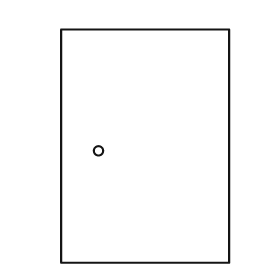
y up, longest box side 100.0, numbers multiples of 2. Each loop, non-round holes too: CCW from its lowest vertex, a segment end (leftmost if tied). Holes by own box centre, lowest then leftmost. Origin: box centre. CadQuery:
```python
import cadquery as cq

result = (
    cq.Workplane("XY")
    .moveTo(-36.0, -50.0)
    .lineTo(36.0, -50.0)
    .lineTo(36.0, 50.0)
    .lineTo(-36.0, 50.0)
    .close()
    .moveTo(-20.0, -2.0)
    .circle(2.0)
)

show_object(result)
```